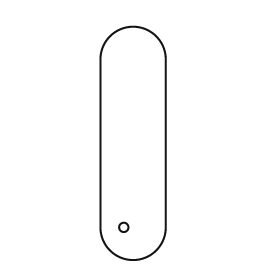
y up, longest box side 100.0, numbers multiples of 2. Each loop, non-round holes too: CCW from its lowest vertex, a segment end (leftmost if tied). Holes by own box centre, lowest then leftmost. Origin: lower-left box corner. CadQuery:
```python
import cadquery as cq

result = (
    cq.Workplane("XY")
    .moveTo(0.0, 14.0)
    .threePointArc((14.0, 0.0), (28.0, 14.0))
    .lineTo(28.0, 86.0)
    .threePointArc((14.0, 100.0), (0.0, 86.0))
    .close()
    .moveTo(10.0, 14.0)
    .circle(2.0)
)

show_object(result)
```